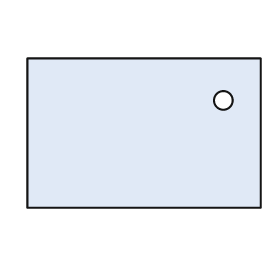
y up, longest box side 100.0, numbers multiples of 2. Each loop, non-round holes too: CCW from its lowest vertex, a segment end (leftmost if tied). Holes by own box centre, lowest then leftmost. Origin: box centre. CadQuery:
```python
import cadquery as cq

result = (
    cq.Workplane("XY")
    .moveTo(-50.0, -32.0)
    .lineTo(50.0, -32.0)
    .lineTo(50.0, 32.0)
    .lineTo(-50.0, 32.0)
    .close()
    .moveTo(34.0, 14.0)
    .circle(4.0)
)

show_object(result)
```